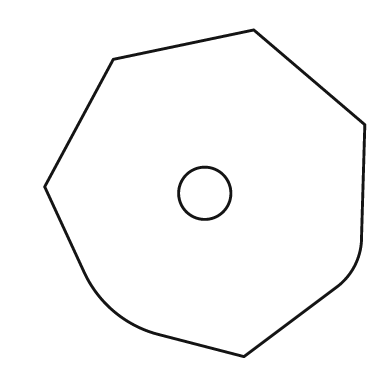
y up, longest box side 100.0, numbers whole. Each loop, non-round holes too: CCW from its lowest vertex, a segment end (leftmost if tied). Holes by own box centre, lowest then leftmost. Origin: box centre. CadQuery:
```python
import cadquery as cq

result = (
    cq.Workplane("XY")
    .moveTo(12.0, -50.0)
    .lineTo(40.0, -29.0)
    .threePointArc((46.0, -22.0), (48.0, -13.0))
    .lineTo(49.0, 21.0)
    .lineTo(15.0, 50.0)
    .lineTo(-28.0, 41.0)
    .lineTo(-49.0, 2.0)
    .lineTo(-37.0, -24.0)
    .threePointArc((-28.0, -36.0), (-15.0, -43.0))
    .close()
    .moveTo(0.0, 0.0)
    .circle(8.0)
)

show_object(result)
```